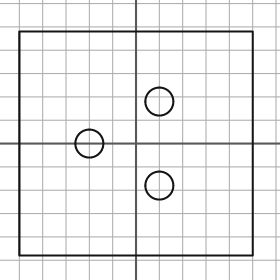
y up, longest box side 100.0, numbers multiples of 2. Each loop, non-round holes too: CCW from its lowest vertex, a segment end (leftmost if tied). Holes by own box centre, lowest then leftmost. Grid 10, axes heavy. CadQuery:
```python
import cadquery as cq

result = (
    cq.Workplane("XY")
    .moveTo(-50.0, -48.0)
    .lineTo(50.0, -48.0)
    .lineTo(50.0, 48.0)
    .lineTo(-50.0, 48.0)
    .close()
    .moveTo(10.0, -18.0)
    .circle(6.0)
    .moveTo(-20.0, 0.0)
    .circle(6.0)
    .moveTo(10.0, 18.0)
    .circle(6.0)
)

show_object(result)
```